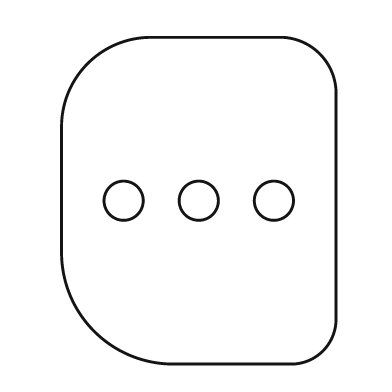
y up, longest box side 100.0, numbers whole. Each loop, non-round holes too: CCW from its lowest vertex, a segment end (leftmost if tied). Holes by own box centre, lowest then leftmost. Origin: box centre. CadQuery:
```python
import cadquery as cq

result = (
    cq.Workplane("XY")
    .moveTo(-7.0, -50.0)
    .lineTo(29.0, -50.0)
    .threePointArc((38.0, -46.0), (42.0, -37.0))
    .lineTo(42.0, 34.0)
    .threePointArc((37.0, 45.0), (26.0, 50.0))
    .lineTo(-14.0, 50.0)
    .threePointArc((-34.0, 42.0), (-42.0, 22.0))
    .lineTo(-42.0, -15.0)
    .threePointArc((-32.0, -40.0), (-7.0, -50.0))
    .close()
    .moveTo(-23.0, 0.0)
    .circle(6.0)
    .moveTo(0.0, 0.0)
    .circle(6.0)
    .moveTo(23.0, 0.0)
    .circle(6.0)
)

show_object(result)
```